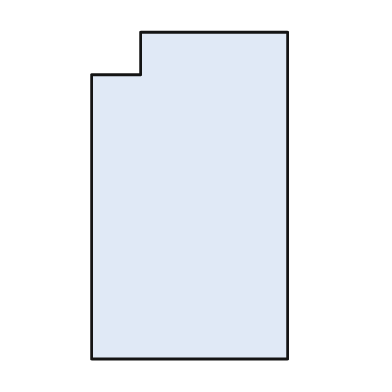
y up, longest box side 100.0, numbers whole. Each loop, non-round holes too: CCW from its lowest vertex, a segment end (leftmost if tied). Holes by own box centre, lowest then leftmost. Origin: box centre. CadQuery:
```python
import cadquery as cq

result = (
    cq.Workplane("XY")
    .moveTo(-30.0, -50.0)
    .lineTo(30.0, -50.0)
    .lineTo(30.0, 50.0)
    .lineTo(-15.0, 50.0)
    .lineTo(-15.0, 37.0)
    .lineTo(-30.0, 37.0)
    .close()
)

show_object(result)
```